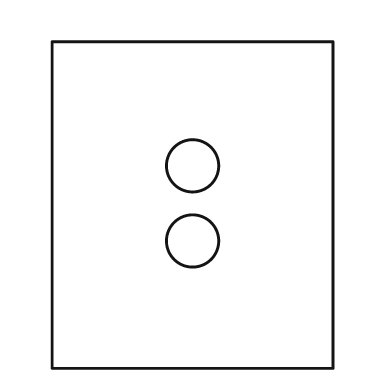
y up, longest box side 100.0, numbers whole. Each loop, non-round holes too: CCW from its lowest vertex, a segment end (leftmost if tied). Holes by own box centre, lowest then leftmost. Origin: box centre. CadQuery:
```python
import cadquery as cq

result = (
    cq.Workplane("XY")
    .moveTo(-43.0, -50.0)
    .lineTo(43.0, -50.0)
    .lineTo(43.0, 50.0)
    .lineTo(-43.0, 50.0)
    .close()
    .moveTo(0.0, -11.0)
    .circle(8.0)
    .moveTo(0.0, 12.0)
    .circle(8.0)
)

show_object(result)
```